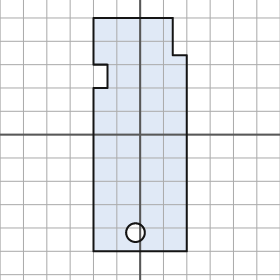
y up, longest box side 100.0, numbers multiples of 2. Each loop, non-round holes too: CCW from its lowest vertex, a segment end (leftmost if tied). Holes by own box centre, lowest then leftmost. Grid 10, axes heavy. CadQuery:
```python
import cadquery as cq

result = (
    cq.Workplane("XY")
    .moveTo(-20.0, -50.0)
    .lineTo(20.0, -50.0)
    .lineTo(20.0, 34.0)
    .lineTo(14.0, 34.0)
    .lineTo(14.0, 50.0)
    .lineTo(-20.0, 50.0)
    .lineTo(-20.0, 30.0)
    .lineTo(-14.0, 30.0)
    .lineTo(-14.0, 20.0)
    .lineTo(-20.0, 20.0)
    .close()
    .moveTo(-2.0, -42.0)
    .circle(4.0)
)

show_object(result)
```